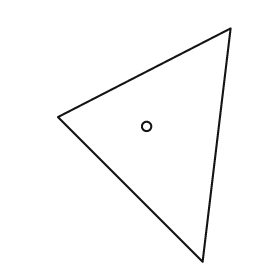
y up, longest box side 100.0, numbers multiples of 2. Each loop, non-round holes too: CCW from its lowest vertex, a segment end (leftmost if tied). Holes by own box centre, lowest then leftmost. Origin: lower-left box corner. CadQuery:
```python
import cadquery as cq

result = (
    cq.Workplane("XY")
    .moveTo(62.0, 0.0)
    .lineTo(74.0, 100.0)
    .lineTo(0.0, 62.0)
    .close()
    .moveTo(38.0, 58.0)
    .circle(2.0)
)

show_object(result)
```